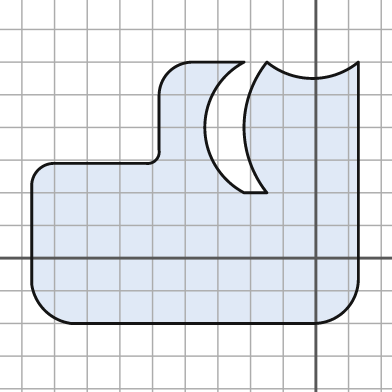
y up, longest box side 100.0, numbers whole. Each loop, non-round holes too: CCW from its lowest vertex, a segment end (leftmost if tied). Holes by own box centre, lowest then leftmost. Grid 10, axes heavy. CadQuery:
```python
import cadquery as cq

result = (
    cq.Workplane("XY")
    .moveTo(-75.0, -20.0)
    .lineTo(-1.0, -20.0)
    .threePointArc((9.0, -16.0), (13.0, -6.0))
    .lineTo(13.0, 60.0)
    .threePointArc((-1.0, 55.0), (-15.0, 60.0))
    .threePointArc((-22.0, 40.0), (-15.0, 20.0))
    .lineTo(-22.0, 20.0)
    .threePointArc((-34.0, 40.0), (-22.0, 60.0))
    .lineTo(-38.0, 60.0)
    .threePointArc((-45.0, 57.0), (-48.0, 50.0))
    .lineTo(-48.0, 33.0)
    .threePointArc((-49.0, 30.0), (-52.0, 29.0))
    .lineTo(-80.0, 29.0)
    .threePointArc((-85.0, 27.0), (-87.0, 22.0))
    .lineTo(-87.0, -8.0)
    .threePointArc((-83.0, -16.0), (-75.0, -20.0))
    .close()
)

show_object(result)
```